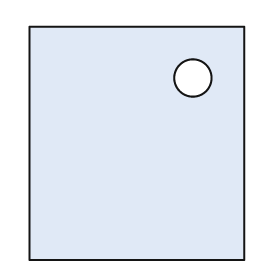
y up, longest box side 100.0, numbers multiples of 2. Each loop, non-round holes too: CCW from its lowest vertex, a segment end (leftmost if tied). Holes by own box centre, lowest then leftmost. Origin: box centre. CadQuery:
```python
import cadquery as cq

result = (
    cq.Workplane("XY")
    .moveTo(-46.0, -50.0)
    .lineTo(46.0, -50.0)
    .lineTo(46.0, 50.0)
    .lineTo(-46.0, 50.0)
    .close()
    .moveTo(24.0, 28.0)
    .circle(8.0)
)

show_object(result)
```